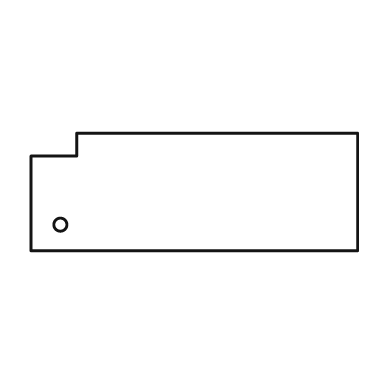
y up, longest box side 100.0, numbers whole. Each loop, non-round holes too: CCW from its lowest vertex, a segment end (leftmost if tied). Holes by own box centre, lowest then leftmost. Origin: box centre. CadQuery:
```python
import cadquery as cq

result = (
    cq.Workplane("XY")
    .moveTo(-50.0, -18.0)
    .lineTo(50.0, -18.0)
    .lineTo(50.0, 18.0)
    .lineTo(-36.0, 18.0)
    .lineTo(-36.0, 11.0)
    .lineTo(-50.0, 11.0)
    .close()
    .moveTo(-41.0, -10.0)
    .circle(2.0)
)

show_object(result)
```